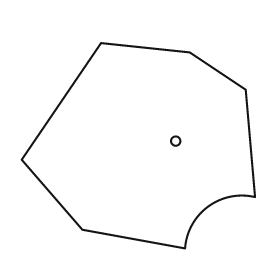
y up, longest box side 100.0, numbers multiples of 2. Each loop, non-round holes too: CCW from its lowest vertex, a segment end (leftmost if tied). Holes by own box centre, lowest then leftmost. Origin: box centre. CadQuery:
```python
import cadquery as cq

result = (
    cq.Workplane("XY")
    .moveTo(20.0, -44.0)
    .threePointArc((30.0, -26.0), (50.0, -22.0))
    .lineTo(46.0, 24.0)
    .lineTo(22.0, 40.0)
    .lineTo(-16.0, 44.0)
    .lineTo(-50.0, -6.0)
    .lineTo(-24.0, -36.0)
    .close()
    .moveTo(16.0, 2.0)
    .circle(2.0)
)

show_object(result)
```